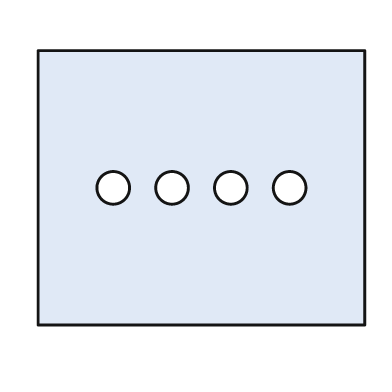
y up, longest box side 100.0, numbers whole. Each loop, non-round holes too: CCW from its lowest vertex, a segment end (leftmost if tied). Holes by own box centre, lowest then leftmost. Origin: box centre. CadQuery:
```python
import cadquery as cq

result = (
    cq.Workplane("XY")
    .moveTo(-50.0, -42.0)
    .lineTo(50.0, -42.0)
    .lineTo(50.0, 42.0)
    .lineTo(-50.0, 42.0)
    .close()
    .moveTo(-27.0, 0.0)
    .circle(5.0)
    .moveTo(-9.0, 0.0)
    .circle(5.0)
    .moveTo(9.0, 0.0)
    .circle(5.0)
    .moveTo(27.0, 0.0)
    .circle(5.0)
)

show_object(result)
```